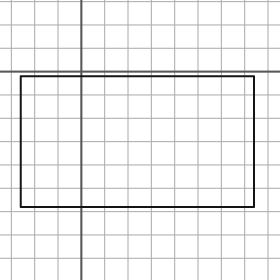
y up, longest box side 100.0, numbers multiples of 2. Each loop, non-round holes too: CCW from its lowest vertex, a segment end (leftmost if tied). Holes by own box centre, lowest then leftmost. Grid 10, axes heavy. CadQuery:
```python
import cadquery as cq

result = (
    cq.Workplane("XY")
    .moveTo(-26.0, -58.0)
    .lineTo(74.0, -58.0)
    .lineTo(74.0, -2.0)
    .lineTo(-26.0, -2.0)
    .close()
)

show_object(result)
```